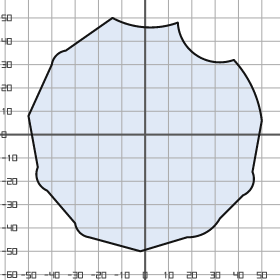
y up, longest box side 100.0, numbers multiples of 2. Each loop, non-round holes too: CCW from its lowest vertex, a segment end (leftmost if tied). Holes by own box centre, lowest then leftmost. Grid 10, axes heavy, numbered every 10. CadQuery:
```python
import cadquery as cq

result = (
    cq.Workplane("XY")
    .moveTo(-2.0, -50.0)
    .lineTo(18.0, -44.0)
    .threePointArc((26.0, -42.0), (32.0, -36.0))
    .lineTo(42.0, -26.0)
    .threePointArc((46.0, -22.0), (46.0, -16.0))
    .lineTo(50.0, 6.0)
    .threePointArc((46.0, 20.0), (38.0, 32.0))
    .threePointArc((22.0, 34.0), (14.0, 48.0))
    .threePointArc((0.0, 46.0), (-14.0, 50.0))
    .lineTo(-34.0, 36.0)
    .threePointArc((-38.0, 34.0), (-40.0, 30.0))
    .lineTo(-50.0, 8.0)
    .lineTo(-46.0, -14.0)
    .threePointArc((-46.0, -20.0), (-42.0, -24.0))
    .lineTo(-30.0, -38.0)
    .threePointArc((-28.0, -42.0), (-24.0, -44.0))
    .close()
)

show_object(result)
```